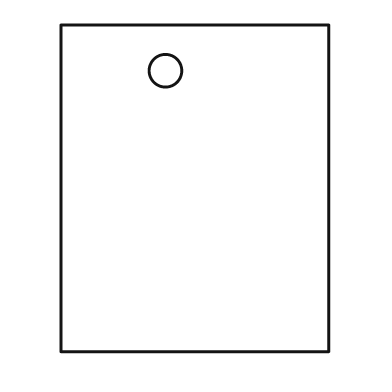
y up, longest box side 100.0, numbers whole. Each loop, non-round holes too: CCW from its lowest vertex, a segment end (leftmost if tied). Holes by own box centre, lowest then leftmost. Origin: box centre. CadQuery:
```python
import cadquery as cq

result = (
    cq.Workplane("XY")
    .moveTo(-41.0, -50.0)
    .lineTo(41.0, -50.0)
    .lineTo(41.0, 50.0)
    .lineTo(-41.0, 50.0)
    .close()
    .moveTo(-9.0, 36.0)
    .circle(5.0)
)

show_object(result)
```